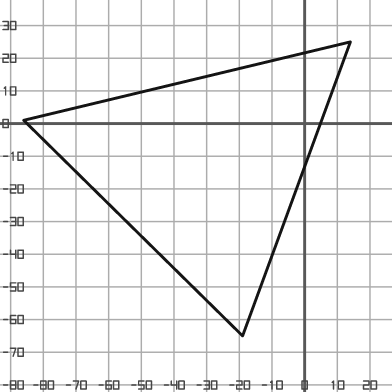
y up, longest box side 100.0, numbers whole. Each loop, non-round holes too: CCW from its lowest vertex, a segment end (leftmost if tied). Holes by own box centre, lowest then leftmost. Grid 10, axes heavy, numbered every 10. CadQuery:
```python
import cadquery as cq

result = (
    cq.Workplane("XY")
    .moveTo(-19.0, -65.0)
    .lineTo(14.0, 25.0)
    .lineTo(-86.0, 1.0)
    .close()
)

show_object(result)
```